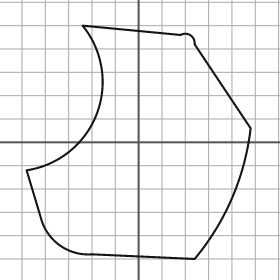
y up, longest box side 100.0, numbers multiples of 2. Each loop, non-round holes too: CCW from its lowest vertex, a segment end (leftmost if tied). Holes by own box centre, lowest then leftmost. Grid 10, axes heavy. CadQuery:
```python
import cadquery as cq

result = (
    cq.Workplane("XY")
    .moveTo(24.0, -50.0)
    .threePointArc((40.0, -24.0), (48.0, 6.0))
    .lineTo(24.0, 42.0)
    .threePointArc((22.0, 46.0), (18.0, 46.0))
    .lineTo(-24.0, 50.0)
    .threePointArc((-18.0, 12.0), (-48.0, -12.0))
    .lineTo(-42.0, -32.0)
    .threePointArc((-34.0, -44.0), (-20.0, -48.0))
    .close()
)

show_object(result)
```